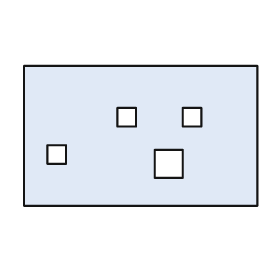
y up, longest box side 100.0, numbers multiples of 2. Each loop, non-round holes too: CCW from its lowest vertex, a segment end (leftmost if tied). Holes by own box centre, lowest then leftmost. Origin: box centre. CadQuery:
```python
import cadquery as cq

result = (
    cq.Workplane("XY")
    .moveTo(-50.0, -30.0)
    .lineTo(50.0, -30.0)
    .lineTo(50.0, 30.0)
    .lineTo(-50.0, 30.0)
    .close()
    .moveTo(6.0, -18.0)
    .lineTo(18.0, -18.0)
    .lineTo(18.0, -6.0)
    .lineTo(6.0, -6.0)
    .close()
    .moveTo(-40.0, -12.0)
    .lineTo(-32.0, -12.0)
    .lineTo(-32.0, -4.0)
    .lineTo(-40.0, -4.0)
    .close()
    .moveTo(-10.0, 4.0)
    .lineTo(-2.0, 4.0)
    .lineTo(-2.0, 12.0)
    .lineTo(-10.0, 12.0)
    .close()
    .moveTo(18.0, 4.0)
    .lineTo(26.0, 4.0)
    .lineTo(26.0, 12.0)
    .lineTo(18.0, 12.0)
    .close()
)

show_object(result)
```